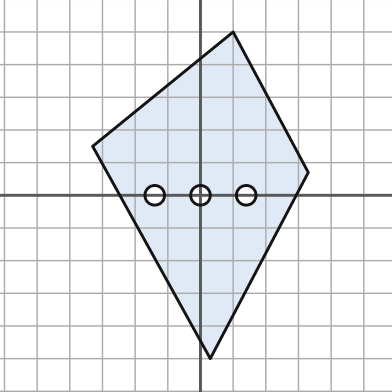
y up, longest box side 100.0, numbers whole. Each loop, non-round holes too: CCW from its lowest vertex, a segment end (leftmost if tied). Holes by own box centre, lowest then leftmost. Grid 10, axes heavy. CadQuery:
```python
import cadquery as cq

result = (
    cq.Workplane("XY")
    .moveTo(3.0, -50.0)
    .lineTo(33.0, 7.0)
    .lineTo(10.0, 50.0)
    .lineTo(-33.0, 15.0)
    .close()
    .moveTo(-14.0, 0.0)
    .circle(3.0)
    .moveTo(0.0, 0.0)
    .circle(3.0)
    .moveTo(14.0, 0.0)
    .circle(3.0)
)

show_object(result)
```